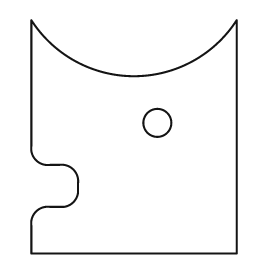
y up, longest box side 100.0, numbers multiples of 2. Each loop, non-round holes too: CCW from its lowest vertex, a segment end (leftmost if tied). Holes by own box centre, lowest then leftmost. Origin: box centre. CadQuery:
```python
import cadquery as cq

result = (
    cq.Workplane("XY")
    .moveTo(-44.0, -50.0)
    .lineTo(44.0, -50.0)
    .lineTo(44.0, 50.0)
    .threePointArc((0.0, 26.0), (-44.0, 50.0))
    .lineTo(-44.0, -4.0)
    .threePointArc((-42.0, -10.0), (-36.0, -12.0))
    .lineTo(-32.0, -12.0)
    .threePointArc((-26.0, -14.0), (-24.0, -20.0))
    .lineTo(-24.0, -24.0)
    .threePointArc((-26.0, -28.0), (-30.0, -30.0))
    .lineTo(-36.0, -30.0)
    .threePointArc((-42.0, -32.0), (-44.0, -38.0))
    .close()
    .moveTo(10.0, 6.0)
    .circle(6.0)
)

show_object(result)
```